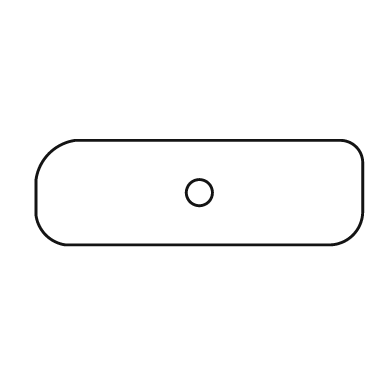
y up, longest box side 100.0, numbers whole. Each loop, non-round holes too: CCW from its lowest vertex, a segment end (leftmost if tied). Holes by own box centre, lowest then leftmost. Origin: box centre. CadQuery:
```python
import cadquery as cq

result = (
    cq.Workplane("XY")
    .moveTo(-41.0, -16.0)
    .lineTo(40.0, -16.0)
    .threePointArc((47.0, -13.0), (50.0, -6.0))
    .lineTo(50.0, 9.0)
    .threePointArc((48.0, 14.0), (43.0, 16.0))
    .lineTo(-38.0, 16.0)
    .threePointArc((-46.0, 12.0), (-50.0, 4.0))
    .lineTo(-50.0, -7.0)
    .threePointArc((-47.0, -13.0), (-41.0, -16.0))
    .close()
    .moveTo(0.0, 0.0)
    .circle(4.0)
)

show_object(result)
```